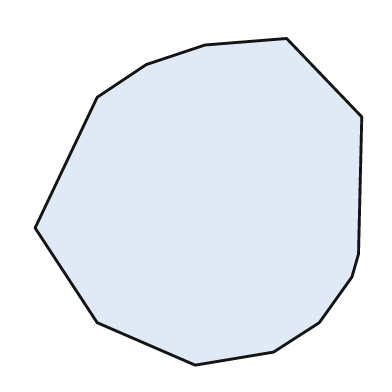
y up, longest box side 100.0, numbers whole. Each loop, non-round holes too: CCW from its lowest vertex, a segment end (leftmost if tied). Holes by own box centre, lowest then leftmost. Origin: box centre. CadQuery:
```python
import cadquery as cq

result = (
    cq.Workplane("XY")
    .moveTo(-1.0, -50.0)
    .lineTo(23.0, -46.0)
    .lineTo(37.0, -37.0)
    .lineTo(47.0, -23.0)
    .lineTo(49.0, -16.0)
    .lineTo(50.0, 26.0)
    .lineTo(27.0, 50.0)
    .lineTo(2.0, 48.0)
    .lineTo(-16.0, 42.0)
    .lineTo(-31.0, 32.0)
    .lineTo(-50.0, -8.0)
    .lineTo(-31.0, -37.0)
    .close()
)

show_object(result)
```